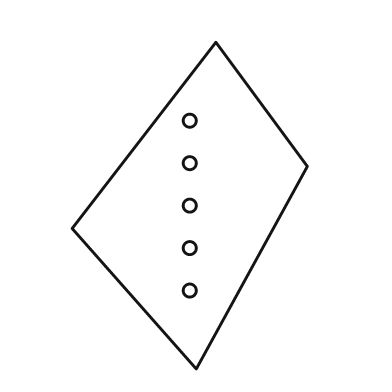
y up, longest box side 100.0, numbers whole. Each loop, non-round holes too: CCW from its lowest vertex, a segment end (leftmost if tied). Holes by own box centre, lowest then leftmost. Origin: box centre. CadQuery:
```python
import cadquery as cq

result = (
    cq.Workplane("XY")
    .moveTo(2.0, -50.0)
    .lineTo(36.0, 12.0)
    .lineTo(8.0, 50.0)
    .lineTo(-36.0, -7.0)
    .close()
    .moveTo(0.0, -26.0)
    .circle(2.0)
    .moveTo(0.0, -13.0)
    .circle(2.0)
    .moveTo(0.0, 0.0)
    .circle(2.0)
    .moveTo(0.0, 13.0)
    .circle(2.0)
    .moveTo(0.0, 26.0)
    .circle(2.0)
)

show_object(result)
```